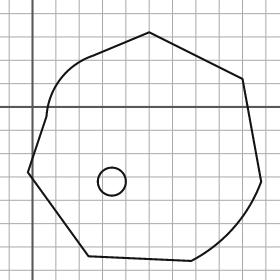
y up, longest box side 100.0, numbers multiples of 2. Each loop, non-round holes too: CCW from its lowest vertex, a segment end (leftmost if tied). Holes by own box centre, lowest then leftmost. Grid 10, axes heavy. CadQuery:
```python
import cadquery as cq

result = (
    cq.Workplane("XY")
    .moveTo(68.0, -66.0)
    .threePointArc((86.0, -52.0), (98.0, -32.0))
    .lineTo(90.0, 12.0)
    .lineTo(50.0, 32.0)
    .lineTo(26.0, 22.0)
    .threePointArc((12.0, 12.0), (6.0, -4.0))
    .lineTo(-2.0, -28.0)
    .lineTo(24.0, -64.0)
    .close()
    .moveTo(34.0, -32.0)
    .circle(6.0)
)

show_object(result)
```